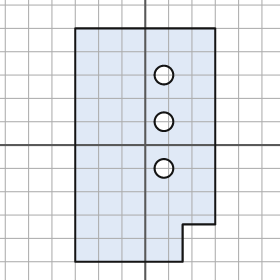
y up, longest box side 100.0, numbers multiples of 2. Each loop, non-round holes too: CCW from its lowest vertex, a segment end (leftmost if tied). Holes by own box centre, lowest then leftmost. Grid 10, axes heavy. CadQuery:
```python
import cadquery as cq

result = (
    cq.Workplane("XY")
    .moveTo(-30.0, -50.0)
    .lineTo(16.0, -50.0)
    .lineTo(16.0, -34.0)
    .lineTo(30.0, -34.0)
    .lineTo(30.0, 50.0)
    .lineTo(-30.0, 50.0)
    .close()
    .moveTo(8.0, -10.0)
    .circle(4.0)
    .moveTo(8.0, 10.0)
    .circle(4.0)
    .moveTo(8.0, 30.0)
    .circle(4.0)
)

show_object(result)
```